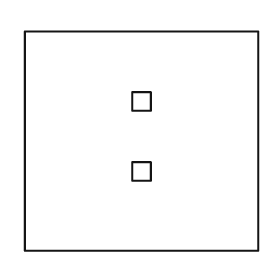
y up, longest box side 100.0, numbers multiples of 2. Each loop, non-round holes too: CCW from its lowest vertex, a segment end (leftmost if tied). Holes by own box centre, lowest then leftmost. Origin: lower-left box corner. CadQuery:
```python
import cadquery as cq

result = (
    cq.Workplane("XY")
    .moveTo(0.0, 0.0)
    .lineTo(100.0, 0.0)
    .lineTo(100.0, 94.0)
    .lineTo(0.0, 94.0)
    .close()
    .moveTo(46.0, 30.0)
    .lineTo(54.0, 30.0)
    .lineTo(54.0, 38.0)
    .lineTo(46.0, 38.0)
    .close()
    .moveTo(46.0, 60.0)
    .lineTo(54.0, 60.0)
    .lineTo(54.0, 68.0)
    .lineTo(46.0, 68.0)
    .close()
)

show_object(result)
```